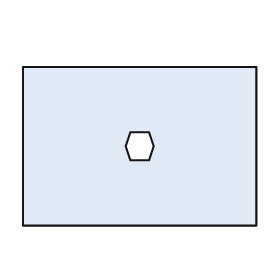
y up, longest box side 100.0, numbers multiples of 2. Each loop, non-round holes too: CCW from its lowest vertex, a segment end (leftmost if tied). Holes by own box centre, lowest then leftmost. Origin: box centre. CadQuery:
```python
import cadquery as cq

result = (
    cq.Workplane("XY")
    .moveTo(-50.0, -34.0)
    .lineTo(50.0, -34.0)
    .lineTo(50.0, 34.0)
    .lineTo(-50.0, 34.0)
    .close()
    .moveTo(-4.0, -6.0)
    .lineTo(4.0, -6.0)
    .lineTo(6.0, 0.0)
    .lineTo(4.0, 6.0)
    .lineTo(-4.0, 6.0)
    .lineTo(-6.0, 0.0)
    .close()
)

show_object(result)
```